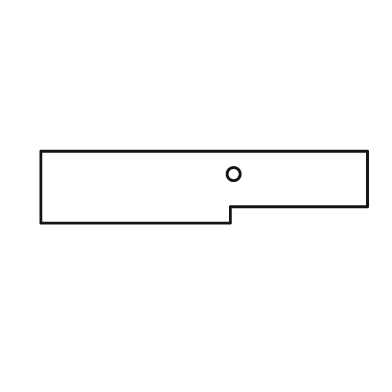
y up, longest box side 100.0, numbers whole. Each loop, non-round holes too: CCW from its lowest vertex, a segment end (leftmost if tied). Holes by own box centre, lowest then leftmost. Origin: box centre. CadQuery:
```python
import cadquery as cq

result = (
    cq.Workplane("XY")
    .moveTo(-50.0, -11.0)
    .lineTo(8.0, -11.0)
    .lineTo(8.0, -6.0)
    .lineTo(50.0, -6.0)
    .lineTo(50.0, 11.0)
    .lineTo(-50.0, 11.0)
    .close()
    .moveTo(9.0, 4.0)
    .circle(2.0)
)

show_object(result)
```